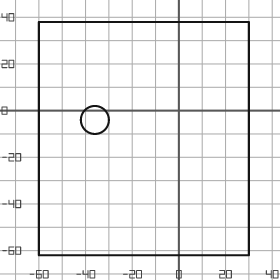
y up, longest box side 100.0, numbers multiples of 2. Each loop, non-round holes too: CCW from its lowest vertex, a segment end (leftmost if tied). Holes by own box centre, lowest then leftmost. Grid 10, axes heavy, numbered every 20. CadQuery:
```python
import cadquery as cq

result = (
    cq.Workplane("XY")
    .moveTo(-60.0, -62.0)
    .lineTo(30.0, -62.0)
    .lineTo(30.0, 38.0)
    .lineTo(-60.0, 38.0)
    .close()
    .moveTo(-36.0, -4.0)
    .circle(6.0)
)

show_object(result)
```